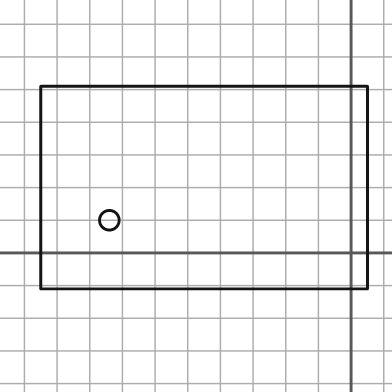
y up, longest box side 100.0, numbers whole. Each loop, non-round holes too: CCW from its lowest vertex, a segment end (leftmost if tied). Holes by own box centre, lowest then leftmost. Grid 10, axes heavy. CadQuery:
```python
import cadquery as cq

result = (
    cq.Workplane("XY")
    .moveTo(-95.0, -11.0)
    .lineTo(5.0, -11.0)
    .lineTo(5.0, 51.0)
    .lineTo(-95.0, 51.0)
    .close()
    .moveTo(-74.0, 10.0)
    .circle(3.0)
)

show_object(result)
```